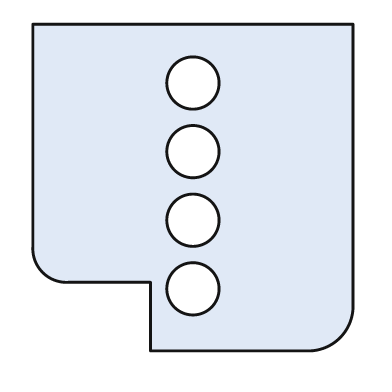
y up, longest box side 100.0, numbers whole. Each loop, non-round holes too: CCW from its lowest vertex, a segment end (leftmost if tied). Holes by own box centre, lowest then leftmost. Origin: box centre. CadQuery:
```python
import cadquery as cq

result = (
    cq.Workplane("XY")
    .moveTo(-13.0, -50.0)
    .lineTo(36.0, -50.0)
    .threePointArc((45.0, -46.0), (49.0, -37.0))
    .lineTo(49.0, 50.0)
    .lineTo(-49.0, 50.0)
    .lineTo(-49.0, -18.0)
    .threePointArc((-46.0, -26.0), (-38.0, -29.0))
    .lineTo(-13.0, -29.0)
    .close()
    .moveTo(0.0, -31.0)
    .circle(8.0)
    .moveTo(0.0, -10.0)
    .circle(8.0)
    .moveTo(0.0, 11.0)
    .circle(8.0)
    .moveTo(0.0, 32.0)
    .circle(8.0)
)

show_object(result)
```